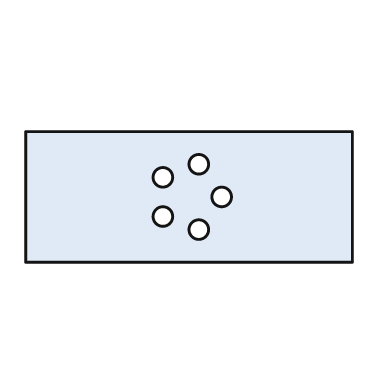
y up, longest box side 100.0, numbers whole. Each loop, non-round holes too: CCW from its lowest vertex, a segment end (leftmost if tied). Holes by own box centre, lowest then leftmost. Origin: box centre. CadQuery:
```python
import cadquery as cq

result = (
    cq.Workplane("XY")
    .moveTo(-50.0, -20.0)
    .lineTo(50.0, -20.0)
    .lineTo(50.0, 20.0)
    .lineTo(-50.0, 20.0)
    .close()
    .moveTo(3.0, -10.0)
    .circle(3.0)
    .moveTo(-8.0, -6.0)
    .circle(3.0)
    .moveTo(10.0, 0.0)
    .circle(3.0)
    .moveTo(-8.0, 6.0)
    .circle(3.0)
    .moveTo(3.0, 10.0)
    .circle(3.0)
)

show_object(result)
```